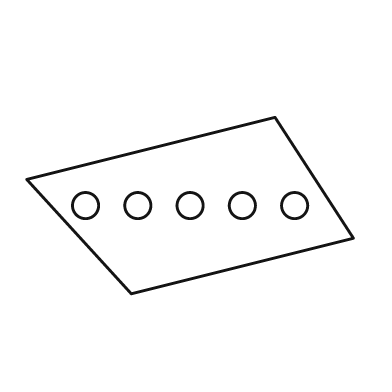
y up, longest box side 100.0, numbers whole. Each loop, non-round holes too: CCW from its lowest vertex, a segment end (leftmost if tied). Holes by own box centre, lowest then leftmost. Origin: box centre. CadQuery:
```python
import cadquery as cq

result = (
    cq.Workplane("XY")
    .moveTo(-18.0, -27.0)
    .lineTo(50.0, -10.0)
    .lineTo(26.0, 27.0)
    .lineTo(-50.0, 8.0)
    .close()
    .moveTo(-32.0, 0.0)
    .circle(4.0)
    .moveTo(-16.0, 0.0)
    .circle(4.0)
    .moveTo(0.0, 0.0)
    .circle(4.0)
    .moveTo(16.0, 0.0)
    .circle(4.0)
    .moveTo(32.0, 0.0)
    .circle(4.0)
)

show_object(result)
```